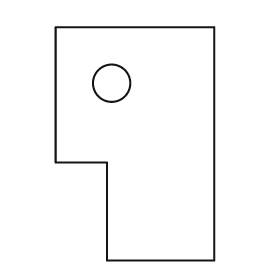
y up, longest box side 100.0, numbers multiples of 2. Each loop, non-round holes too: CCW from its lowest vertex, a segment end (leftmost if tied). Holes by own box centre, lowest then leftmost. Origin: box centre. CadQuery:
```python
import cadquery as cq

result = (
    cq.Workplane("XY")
    .moveTo(-12.0, -50.0)
    .lineTo(34.0, -50.0)
    .lineTo(34.0, 50.0)
    .lineTo(-34.0, 50.0)
    .lineTo(-34.0, -8.0)
    .lineTo(-12.0, -8.0)
    .close()
    .moveTo(-10.0, 26.0)
    .circle(8.0)
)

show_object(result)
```